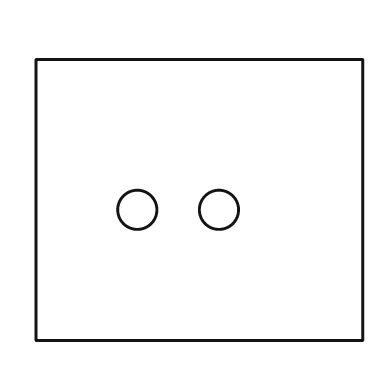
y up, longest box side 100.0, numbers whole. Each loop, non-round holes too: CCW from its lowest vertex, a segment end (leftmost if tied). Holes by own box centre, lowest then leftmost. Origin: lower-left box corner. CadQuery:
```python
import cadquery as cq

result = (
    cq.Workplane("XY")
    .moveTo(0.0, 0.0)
    .lineTo(100.0, 0.0)
    .lineTo(100.0, 86.0)
    .lineTo(0.0, 86.0)
    .close()
    .moveTo(31.0, 40.0)
    .circle(6.0)
    .moveTo(56.0, 40.0)
    .circle(6.0)
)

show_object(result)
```